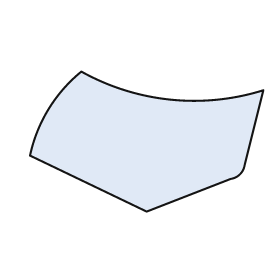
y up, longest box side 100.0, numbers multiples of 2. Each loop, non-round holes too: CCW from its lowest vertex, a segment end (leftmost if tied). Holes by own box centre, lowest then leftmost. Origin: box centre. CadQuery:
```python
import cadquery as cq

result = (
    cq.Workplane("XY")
    .moveTo(0.0, -30.0)
    .lineTo(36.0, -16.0)
    .threePointArc((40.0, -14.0), (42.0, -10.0))
    .lineTo(50.0, 22.0)
    .threePointArc((10.0, 18.0), (-28.0, 30.0))
    .threePointArc((-42.0, 14.0), (-50.0, -6.0))
    .close()
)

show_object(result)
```